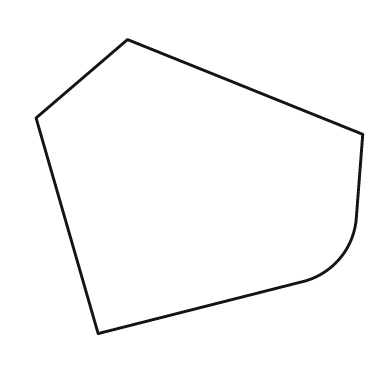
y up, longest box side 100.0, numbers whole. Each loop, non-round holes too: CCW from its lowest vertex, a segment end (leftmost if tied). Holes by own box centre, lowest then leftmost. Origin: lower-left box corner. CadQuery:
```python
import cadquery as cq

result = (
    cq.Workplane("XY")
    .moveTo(19.0, 0.0)
    .lineTo(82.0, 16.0)
    .threePointArc((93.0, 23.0), (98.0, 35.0))
    .lineTo(100.0, 61.0)
    .lineTo(28.0, 90.0)
    .lineTo(0.0, 66.0)
    .close()
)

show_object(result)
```